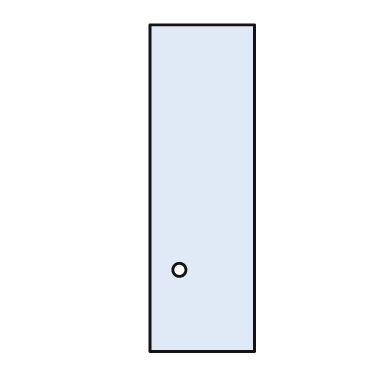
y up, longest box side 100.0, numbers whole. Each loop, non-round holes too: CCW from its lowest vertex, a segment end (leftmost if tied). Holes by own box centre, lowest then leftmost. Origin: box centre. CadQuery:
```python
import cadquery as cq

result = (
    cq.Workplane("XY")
    .moveTo(-16.0, -50.0)
    .lineTo(16.0, -50.0)
    .lineTo(16.0, 50.0)
    .lineTo(-16.0, 50.0)
    .close()
    .moveTo(-7.0, -25.0)
    .circle(2.0)
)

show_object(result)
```